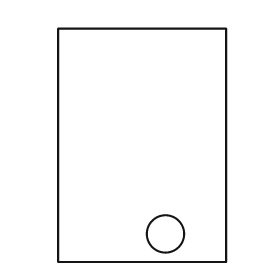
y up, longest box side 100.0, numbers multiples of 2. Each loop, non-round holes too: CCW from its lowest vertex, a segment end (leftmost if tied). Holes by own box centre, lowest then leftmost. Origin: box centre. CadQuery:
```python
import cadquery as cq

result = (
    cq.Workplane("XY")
    .moveTo(-36.0, -50.0)
    .lineTo(36.0, -50.0)
    .lineTo(36.0, 50.0)
    .lineTo(-36.0, 50.0)
    .close()
    .moveTo(10.0, -38.0)
    .circle(8.0)
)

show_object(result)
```